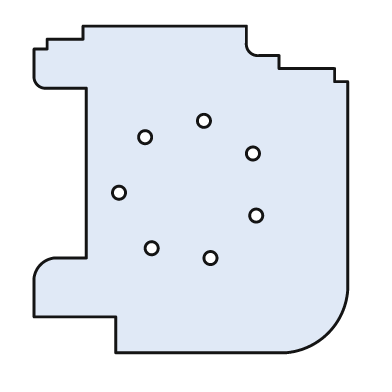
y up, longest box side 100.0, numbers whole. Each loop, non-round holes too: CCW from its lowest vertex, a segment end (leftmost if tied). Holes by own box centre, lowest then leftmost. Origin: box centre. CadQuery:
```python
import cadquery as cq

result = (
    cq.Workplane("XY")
    .moveTo(-23.0, -50.0)
    .lineTo(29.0, -50.0)
    .threePointArc((42.0, -44.0), (48.0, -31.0))
    .lineTo(48.0, 33.0)
    .lineTo(44.0, 33.0)
    .lineTo(44.0, 37.0)
    .lineTo(27.0, 37.0)
    .lineTo(27.0, 41.0)
    .lineTo(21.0, 41.0)
    .threePointArc((18.0, 42.0), (17.0, 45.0))
    .lineTo(17.0, 50.0)
    .lineTo(-33.0, 50.0)
    .lineTo(-33.0, 46.0)
    .lineTo(-44.0, 46.0)
    .lineTo(-44.0, 43.0)
    .lineTo(-48.0, 43.0)
    .lineTo(-48.0, 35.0)
    .threePointArc((-47.0, 32.0), (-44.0, 31.0))
    .lineTo(-32.0, 31.0)
    .lineTo(-32.0, -21.0)
    .lineTo(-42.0, -21.0)
    .threePointArc((-46.0, -23.0), (-48.0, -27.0))
    .lineTo(-48.0, -39.0)
    .lineTo(-23.0, -39.0)
    .close()
    .moveTo(6.0, -21.0)
    .circle(2.0)
    .moveTo(-12.0, -18.0)
    .circle(2.0)
    .moveTo(20.0, -8.0)
    .circle(2.0)
    .moveTo(-22.0, -1.0)
    .circle(2.0)
    .moveTo(19.0, 11.0)
    .circle(2.0)
    .moveTo(-14.0, 16.0)
    .circle(2.0)
    .moveTo(4.0, 21.0)
    .circle(2.0)
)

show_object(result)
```